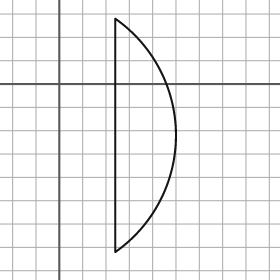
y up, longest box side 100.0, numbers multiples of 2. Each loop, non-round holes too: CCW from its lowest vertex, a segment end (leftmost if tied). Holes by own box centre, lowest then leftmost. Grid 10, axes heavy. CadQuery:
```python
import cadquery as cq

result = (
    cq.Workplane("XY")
    .moveTo(24.0, -72.0)
    .threePointArc((50.0, -22.0), (24.0, 28.0))
    .close()
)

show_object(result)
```